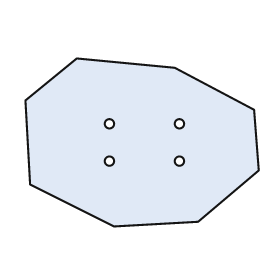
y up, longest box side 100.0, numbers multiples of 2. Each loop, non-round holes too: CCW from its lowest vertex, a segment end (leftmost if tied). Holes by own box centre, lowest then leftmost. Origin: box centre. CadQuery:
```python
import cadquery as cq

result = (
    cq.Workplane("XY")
    .moveTo(-12.0, -36.0)
    .lineTo(24.0, -34.0)
    .lineTo(50.0, -12.0)
    .lineTo(48.0, 14.0)
    .lineTo(14.0, 32.0)
    .lineTo(-28.0, 36.0)
    .lineTo(-50.0, 18.0)
    .lineTo(-48.0, -18.0)
    .close()
    .moveTo(-14.0, -8.0)
    .circle(2.0)
    .moveTo(16.0, -8.0)
    .circle(2.0)
    .moveTo(-14.0, 8.0)
    .circle(2.0)
    .moveTo(16.0, 8.0)
    .circle(2.0)
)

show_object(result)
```